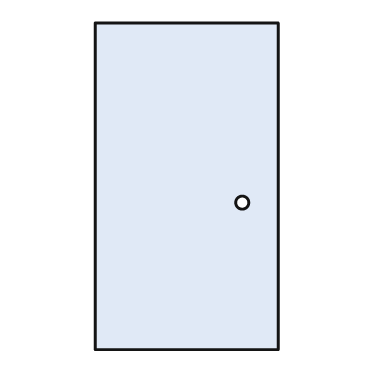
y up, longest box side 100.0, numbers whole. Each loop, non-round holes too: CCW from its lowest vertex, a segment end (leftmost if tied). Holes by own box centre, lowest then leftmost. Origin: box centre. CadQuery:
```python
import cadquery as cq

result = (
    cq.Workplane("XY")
    .moveTo(-28.0, -50.0)
    .lineTo(28.0, -50.0)
    .lineTo(28.0, 50.0)
    .lineTo(-28.0, 50.0)
    .close()
    .moveTo(17.0, -5.0)
    .circle(2.0)
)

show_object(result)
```